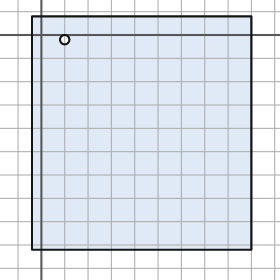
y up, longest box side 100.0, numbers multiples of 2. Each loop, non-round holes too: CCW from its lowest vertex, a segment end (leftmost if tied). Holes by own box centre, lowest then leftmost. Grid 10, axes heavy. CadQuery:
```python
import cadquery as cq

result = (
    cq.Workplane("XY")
    .moveTo(-4.0, -92.0)
    .lineTo(90.0, -92.0)
    .lineTo(90.0, 8.0)
    .lineTo(-4.0, 8.0)
    .close()
    .moveTo(10.0, -2.0)
    .circle(2.0)
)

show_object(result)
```